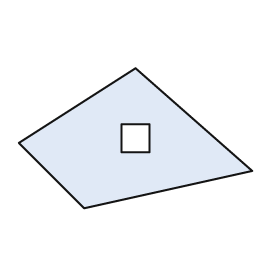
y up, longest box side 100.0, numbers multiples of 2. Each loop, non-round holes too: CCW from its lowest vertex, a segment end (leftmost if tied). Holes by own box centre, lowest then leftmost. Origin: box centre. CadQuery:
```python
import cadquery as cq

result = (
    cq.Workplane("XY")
    .moveTo(-22.0, -30.0)
    .lineTo(50.0, -14.0)
    .lineTo(0.0, 30.0)
    .lineTo(-50.0, -2.0)
    .close()
    .moveTo(-6.0, -6.0)
    .lineTo(6.0, -6.0)
    .lineTo(6.0, 6.0)
    .lineTo(-6.0, 6.0)
    .close()
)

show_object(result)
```